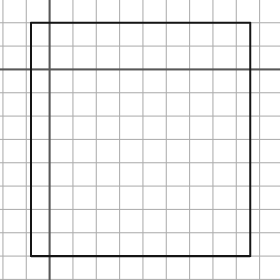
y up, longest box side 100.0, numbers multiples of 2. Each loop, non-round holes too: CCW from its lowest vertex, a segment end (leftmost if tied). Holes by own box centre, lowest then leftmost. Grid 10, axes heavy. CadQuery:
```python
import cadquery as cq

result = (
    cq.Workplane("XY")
    .moveTo(-8.0, -80.0)
    .lineTo(86.0, -80.0)
    .lineTo(86.0, 20.0)
    .lineTo(-8.0, 20.0)
    .close()
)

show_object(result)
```